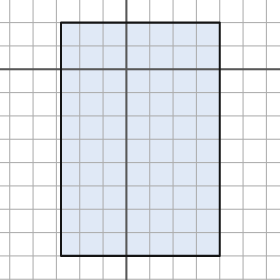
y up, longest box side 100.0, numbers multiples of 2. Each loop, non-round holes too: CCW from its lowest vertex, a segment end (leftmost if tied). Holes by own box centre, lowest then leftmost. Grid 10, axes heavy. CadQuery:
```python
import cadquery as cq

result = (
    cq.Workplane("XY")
    .moveTo(-28.0, -80.0)
    .lineTo(40.0, -80.0)
    .lineTo(40.0, 20.0)
    .lineTo(-28.0, 20.0)
    .close()
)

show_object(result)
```